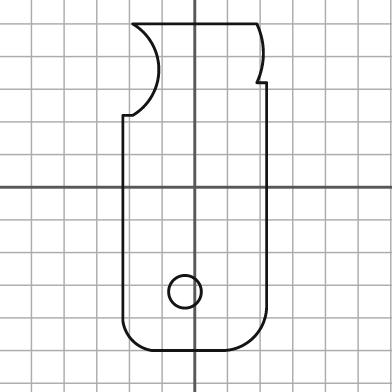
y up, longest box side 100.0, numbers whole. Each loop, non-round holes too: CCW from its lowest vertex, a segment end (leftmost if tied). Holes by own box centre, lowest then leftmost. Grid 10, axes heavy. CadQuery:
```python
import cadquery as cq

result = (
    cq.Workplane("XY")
    .moveTo(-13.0, -50.0)
    .lineTo(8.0, -50.0)
    .threePointArc((18.0, -46.0), (22.0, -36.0))
    .lineTo(22.0, 32.0)
    .lineTo(19.0, 32.0)
    .threePointArc((21.0, 41.0), (19.0, 50.0))
    .lineTo(-19.0, 50.0)
    .threePointArc((-11.0, 36.0), (-19.0, 22.0))
    .lineTo(-22.0, 22.0)
    .lineTo(-22.0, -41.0)
    .threePointArc((-19.0, -47.0), (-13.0, -50.0))
    .close()
    .moveTo(-3.0, -32.0)
    .circle(5.0)
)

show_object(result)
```